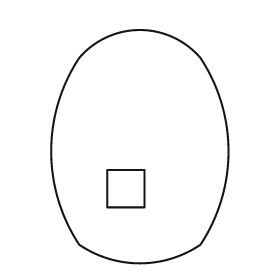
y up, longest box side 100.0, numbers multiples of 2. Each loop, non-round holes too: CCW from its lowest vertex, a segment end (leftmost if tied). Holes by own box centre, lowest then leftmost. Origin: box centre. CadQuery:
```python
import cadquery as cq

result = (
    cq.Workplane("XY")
    .moveTo(-26.0, -42.0)
    .threePointArc((0.0, -50.0), (26.0, -42.0))
    .threePointArc((38.0, -2.0), (26.0, 38.0))
    .threePointArc((0.0, 50.0), (-26.0, 38.0))
    .threePointArc((-38.0, -2.0), (-26.0, -42.0))
    .close()
    .moveTo(-14.0, -26.0)
    .lineTo(2.0, -26.0)
    .lineTo(2.0, -10.0)
    .lineTo(-14.0, -10.0)
    .close()
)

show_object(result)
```